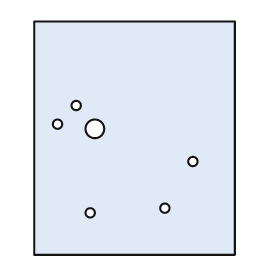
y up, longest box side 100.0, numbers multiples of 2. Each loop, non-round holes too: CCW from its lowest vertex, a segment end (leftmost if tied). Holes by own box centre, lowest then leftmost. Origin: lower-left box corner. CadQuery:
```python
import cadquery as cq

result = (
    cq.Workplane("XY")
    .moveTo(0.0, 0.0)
    .lineTo(86.0, 0.0)
    .lineTo(86.0, 100.0)
    .lineTo(0.0, 100.0)
    .close()
    .moveTo(24.0, 18.0)
    .circle(2.0)
    .moveTo(56.0, 20.0)
    .circle(2.0)
    .moveTo(68.0, 40.0)
    .circle(2.0)
    .moveTo(26.0, 54.0)
    .circle(4.0)
    .moveTo(10.0, 56.0)
    .circle(2.0)
    .moveTo(18.0, 64.0)
    .circle(2.0)
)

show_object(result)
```